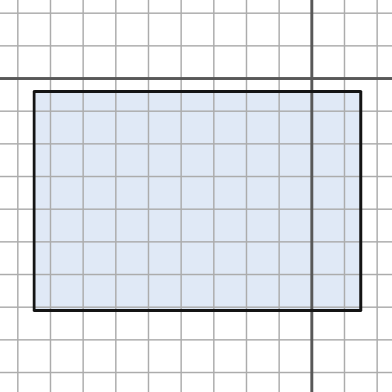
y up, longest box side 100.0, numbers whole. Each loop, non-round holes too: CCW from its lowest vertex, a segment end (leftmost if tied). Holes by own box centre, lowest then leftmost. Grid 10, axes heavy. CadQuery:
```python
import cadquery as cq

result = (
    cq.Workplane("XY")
    .moveTo(-85.0, -71.0)
    .lineTo(15.0, -71.0)
    .lineTo(15.0, -4.0)
    .lineTo(-85.0, -4.0)
    .close()
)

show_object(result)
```